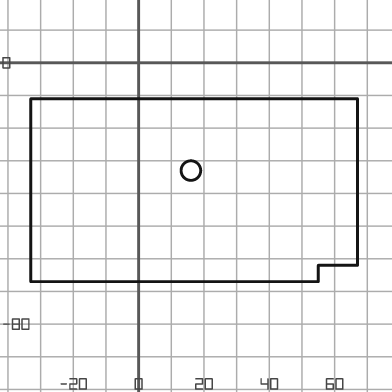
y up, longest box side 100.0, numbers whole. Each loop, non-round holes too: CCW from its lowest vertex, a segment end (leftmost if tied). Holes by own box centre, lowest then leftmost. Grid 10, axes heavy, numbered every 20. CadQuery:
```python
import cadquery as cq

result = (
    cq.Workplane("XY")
    .moveTo(-33.0, -67.0)
    .lineTo(55.0, -67.0)
    .lineTo(55.0, -62.0)
    .lineTo(67.0, -62.0)
    .lineTo(67.0, -11.0)
    .lineTo(-33.0, -11.0)
    .close()
    .moveTo(16.0, -33.0)
    .circle(3.0)
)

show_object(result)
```